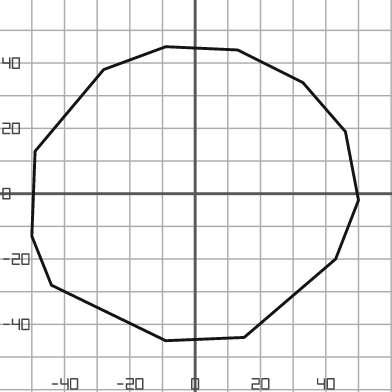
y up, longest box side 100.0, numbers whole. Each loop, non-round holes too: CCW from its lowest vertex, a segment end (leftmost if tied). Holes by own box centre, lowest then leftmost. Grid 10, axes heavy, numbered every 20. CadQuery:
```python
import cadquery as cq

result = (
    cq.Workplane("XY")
    .moveTo(-9.0, -45.0)
    .lineTo(15.0, -44.0)
    .lineTo(43.0, -20.0)
    .lineTo(50.0, -2.0)
    .lineTo(46.0, 19.0)
    .lineTo(33.0, 34.0)
    .lineTo(13.0, 44.0)
    .lineTo(-9.0, 45.0)
    .lineTo(-28.0, 38.0)
    .lineTo(-49.0, 13.0)
    .lineTo(-50.0, -13.0)
    .lineTo(-44.0, -28.0)
    .close()
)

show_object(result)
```